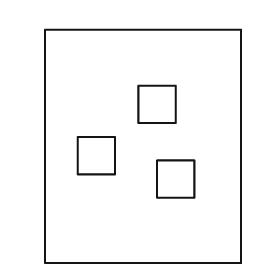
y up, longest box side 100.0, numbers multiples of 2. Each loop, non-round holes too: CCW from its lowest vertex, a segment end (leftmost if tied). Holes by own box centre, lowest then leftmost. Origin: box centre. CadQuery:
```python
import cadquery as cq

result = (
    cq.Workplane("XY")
    .moveTo(-42.0, -50.0)
    .lineTo(42.0, -50.0)
    .lineTo(42.0, 50.0)
    .lineTo(-42.0, 50.0)
    .close()
    .moveTo(6.0, -22.0)
    .lineTo(22.0, -22.0)
    .lineTo(22.0, -6.0)
    .lineTo(6.0, -6.0)
    .close()
    .moveTo(-28.0, -12.0)
    .lineTo(-12.0, -12.0)
    .lineTo(-12.0, 4.0)
    .lineTo(-28.0, 4.0)
    .close()
    .moveTo(-2.0, 10.0)
    .lineTo(14.0, 10.0)
    .lineTo(14.0, 26.0)
    .lineTo(-2.0, 26.0)
    .close()
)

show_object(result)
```